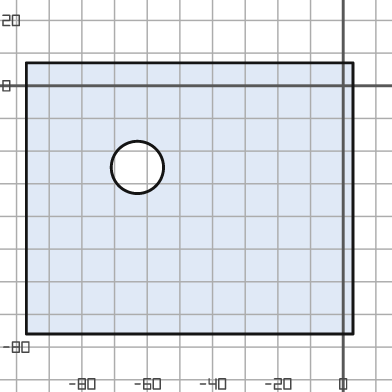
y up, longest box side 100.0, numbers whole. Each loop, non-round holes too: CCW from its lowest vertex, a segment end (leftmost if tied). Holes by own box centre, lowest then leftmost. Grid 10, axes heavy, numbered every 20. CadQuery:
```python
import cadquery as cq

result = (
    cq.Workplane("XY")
    .moveTo(-97.0, -76.0)
    .lineTo(3.0, -76.0)
    .lineTo(3.0, 7.0)
    .lineTo(-97.0, 7.0)
    .close()
    .moveTo(-63.0, -25.0)
    .circle(8.0)
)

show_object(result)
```